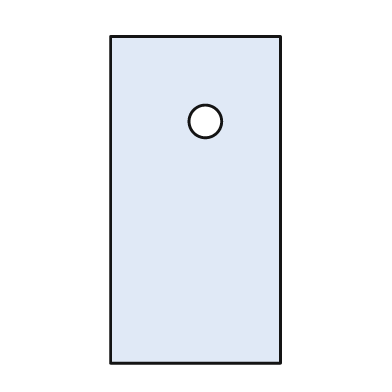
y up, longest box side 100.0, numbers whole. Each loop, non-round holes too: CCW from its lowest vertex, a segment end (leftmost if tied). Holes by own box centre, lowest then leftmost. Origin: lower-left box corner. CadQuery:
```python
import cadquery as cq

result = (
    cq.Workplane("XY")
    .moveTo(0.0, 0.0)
    .lineTo(52.0, 0.0)
    .lineTo(52.0, 100.0)
    .lineTo(0.0, 100.0)
    .close()
    .moveTo(29.0, 74.0)
    .circle(5.0)
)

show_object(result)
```